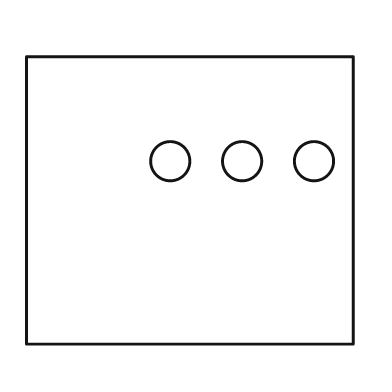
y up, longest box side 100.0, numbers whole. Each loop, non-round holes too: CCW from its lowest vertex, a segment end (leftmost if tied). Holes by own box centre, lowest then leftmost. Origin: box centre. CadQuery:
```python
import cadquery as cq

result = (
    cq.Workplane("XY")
    .moveTo(-50.0, -44.0)
    .lineTo(50.0, -44.0)
    .lineTo(50.0, 44.0)
    .lineTo(-50.0, 44.0)
    .close()
    .moveTo(-6.0, 12.0)
    .circle(6.0)
    .moveTo(16.0, 12.0)
    .circle(6.0)
    .moveTo(38.0, 12.0)
    .circle(6.0)
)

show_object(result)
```